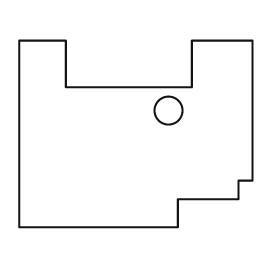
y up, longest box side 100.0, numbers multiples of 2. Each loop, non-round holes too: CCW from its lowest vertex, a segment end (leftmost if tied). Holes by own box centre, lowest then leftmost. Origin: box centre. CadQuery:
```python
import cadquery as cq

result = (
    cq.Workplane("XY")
    .moveTo(-50.0, -40.0)
    .lineTo(18.0, -40.0)
    .lineTo(18.0, -28.0)
    .lineTo(44.0, -28.0)
    .lineTo(44.0, -20.0)
    .lineTo(50.0, -20.0)
    .lineTo(50.0, 40.0)
    .lineTo(24.0, 40.0)
    .lineTo(24.0, 20.0)
    .lineTo(-30.0, 20.0)
    .lineTo(-30.0, 40.0)
    .lineTo(-50.0, 40.0)
    .close()
    .moveTo(14.0, 10.0)
    .circle(6.0)
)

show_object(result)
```